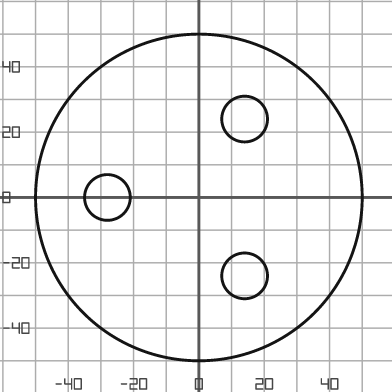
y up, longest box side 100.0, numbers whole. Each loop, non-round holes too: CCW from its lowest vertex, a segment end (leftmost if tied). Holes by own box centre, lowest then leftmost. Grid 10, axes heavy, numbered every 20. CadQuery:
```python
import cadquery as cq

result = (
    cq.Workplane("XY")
    .moveTo(0.0, 0.0)
    .circle(50.0)
    .moveTo(14.0, -24.0)
    .circle(7.0)
    .moveTo(-28.0, 0.0)
    .circle(7.0)
    .moveTo(14.0, 24.0)
    .circle(7.0)
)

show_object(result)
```